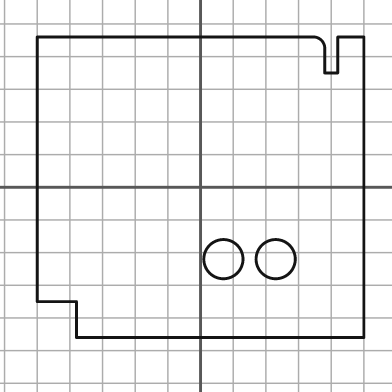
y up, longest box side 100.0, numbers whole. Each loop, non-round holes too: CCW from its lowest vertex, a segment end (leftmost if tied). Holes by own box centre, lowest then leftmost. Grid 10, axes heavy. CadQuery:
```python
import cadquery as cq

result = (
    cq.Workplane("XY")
    .moveTo(-38.0, -46.0)
    .lineTo(50.0, -46.0)
    .lineTo(50.0, 46.0)
    .lineTo(42.0, 46.0)
    .lineTo(42.0, 35.0)
    .lineTo(38.0, 35.0)
    .lineTo(38.0, 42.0)
    .threePointArc((37.0, 45.0), (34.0, 46.0))
    .lineTo(-50.0, 46.0)
    .lineTo(-50.0, -35.0)
    .lineTo(-38.0, -35.0)
    .close()
    .moveTo(7.0, -22.0)
    .circle(6.0)
    .moveTo(23.0, -22.0)
    .circle(6.0)
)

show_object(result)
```